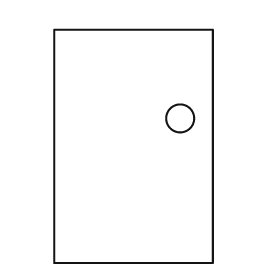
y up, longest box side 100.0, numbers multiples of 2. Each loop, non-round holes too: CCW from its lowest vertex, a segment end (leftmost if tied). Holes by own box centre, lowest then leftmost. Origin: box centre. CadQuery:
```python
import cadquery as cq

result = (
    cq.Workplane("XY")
    .moveTo(-34.0, -50.0)
    .lineTo(34.0, -50.0)
    .lineTo(34.0, 50.0)
    .lineTo(-34.0, 50.0)
    .close()
    .moveTo(20.0, 12.0)
    .circle(6.0)
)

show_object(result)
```